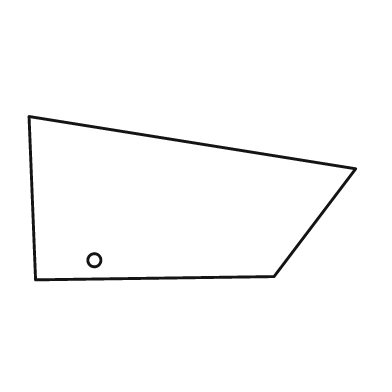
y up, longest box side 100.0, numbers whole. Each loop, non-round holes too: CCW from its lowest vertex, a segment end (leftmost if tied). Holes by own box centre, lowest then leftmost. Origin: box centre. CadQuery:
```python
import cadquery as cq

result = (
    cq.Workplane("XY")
    .moveTo(-48.0, -25.0)
    .lineTo(25.0, -24.0)
    .lineTo(50.0, 9.0)
    .lineTo(-50.0, 25.0)
    .close()
    .moveTo(-30.0, -19.0)
    .circle(2.0)
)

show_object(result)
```